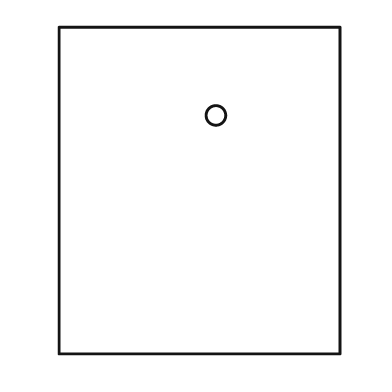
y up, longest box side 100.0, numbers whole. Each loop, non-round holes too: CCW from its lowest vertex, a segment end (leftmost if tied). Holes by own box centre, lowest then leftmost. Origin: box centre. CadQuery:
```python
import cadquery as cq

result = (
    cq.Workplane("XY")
    .moveTo(-43.0, -50.0)
    .lineTo(43.0, -50.0)
    .lineTo(43.0, 50.0)
    .lineTo(-43.0, 50.0)
    .close()
    .moveTo(5.0, 23.0)
    .circle(3.0)
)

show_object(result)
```